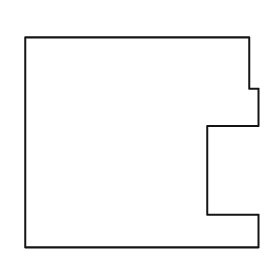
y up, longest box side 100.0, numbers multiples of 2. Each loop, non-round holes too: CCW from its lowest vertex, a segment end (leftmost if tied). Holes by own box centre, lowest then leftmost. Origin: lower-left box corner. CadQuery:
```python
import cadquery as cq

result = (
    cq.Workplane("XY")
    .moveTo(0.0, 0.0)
    .lineTo(100.0, 0.0)
    .lineTo(100.0, 14.0)
    .lineTo(78.0, 14.0)
    .lineTo(78.0, 52.0)
    .lineTo(100.0, 52.0)
    .lineTo(100.0, 68.0)
    .lineTo(96.0, 68.0)
    .lineTo(96.0, 90.0)
    .lineTo(0.0, 90.0)
    .close()
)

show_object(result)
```